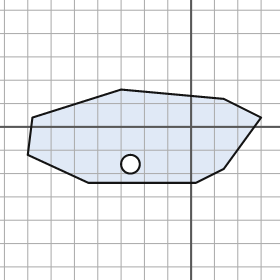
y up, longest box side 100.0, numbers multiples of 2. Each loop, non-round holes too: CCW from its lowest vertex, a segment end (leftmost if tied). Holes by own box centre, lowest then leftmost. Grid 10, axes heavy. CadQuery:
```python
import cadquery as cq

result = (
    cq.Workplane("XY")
    .moveTo(-44.0, -24.0)
    .lineTo(2.0, -24.0)
    .lineTo(14.0, -18.0)
    .lineTo(30.0, 4.0)
    .lineTo(14.0, 12.0)
    .lineTo(-30.0, 16.0)
    .lineTo(-68.0, 4.0)
    .lineTo(-70.0, -12.0)
    .close()
    .moveTo(-26.0, -16.0)
    .circle(4.0)
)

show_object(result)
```